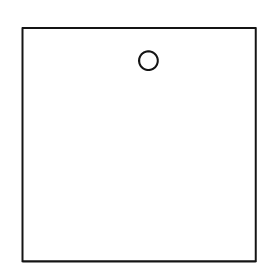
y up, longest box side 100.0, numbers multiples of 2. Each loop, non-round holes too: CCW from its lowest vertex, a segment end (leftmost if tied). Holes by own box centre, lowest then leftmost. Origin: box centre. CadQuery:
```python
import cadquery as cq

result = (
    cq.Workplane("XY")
    .moveTo(-50.0, -50.0)
    .lineTo(50.0, -50.0)
    .lineTo(50.0, 50.0)
    .lineTo(-50.0, 50.0)
    .close()
    .moveTo(4.0, 36.0)
    .circle(4.0)
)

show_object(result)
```